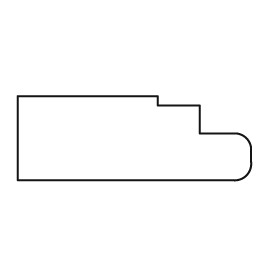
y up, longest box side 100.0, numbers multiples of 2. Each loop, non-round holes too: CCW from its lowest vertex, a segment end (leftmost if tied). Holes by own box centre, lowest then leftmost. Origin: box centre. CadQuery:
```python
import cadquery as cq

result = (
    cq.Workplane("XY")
    .moveTo(-50.0, -18.0)
    .lineTo(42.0, -18.0)
    .threePointArc((48.0, -16.0), (50.0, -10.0))
    .lineTo(50.0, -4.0)
    .threePointArc((48.0, 0.0), (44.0, 2.0))
    .lineTo(28.0, 2.0)
    .lineTo(28.0, 14.0)
    .lineTo(10.0, 14.0)
    .lineTo(10.0, 18.0)
    .lineTo(-50.0, 18.0)
    .close()
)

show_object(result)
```